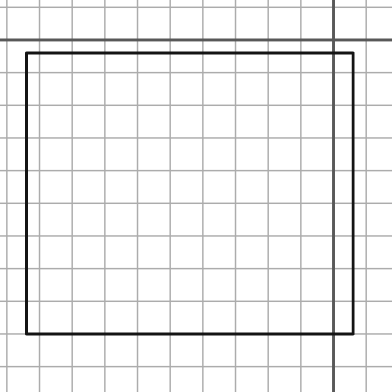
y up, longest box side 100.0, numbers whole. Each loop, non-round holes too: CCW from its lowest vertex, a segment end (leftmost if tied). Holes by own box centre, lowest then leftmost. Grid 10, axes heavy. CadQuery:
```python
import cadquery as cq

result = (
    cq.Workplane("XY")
    .moveTo(-94.0, -90.0)
    .lineTo(6.0, -90.0)
    .lineTo(6.0, -4.0)
    .lineTo(-94.0, -4.0)
    .close()
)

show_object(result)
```